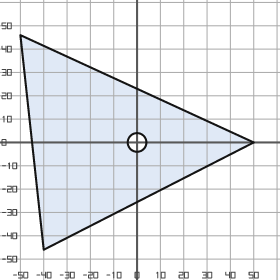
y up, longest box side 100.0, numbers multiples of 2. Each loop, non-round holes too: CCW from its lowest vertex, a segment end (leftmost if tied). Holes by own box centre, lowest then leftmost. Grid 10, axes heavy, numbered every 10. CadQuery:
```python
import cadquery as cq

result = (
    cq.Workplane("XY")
    .moveTo(-40.0, -46.0)
    .lineTo(50.0, 0.0)
    .lineTo(-50.0, 46.0)
    .close()
    .moveTo(0.0, 0.0)
    .circle(4.0)
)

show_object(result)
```